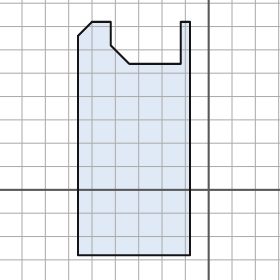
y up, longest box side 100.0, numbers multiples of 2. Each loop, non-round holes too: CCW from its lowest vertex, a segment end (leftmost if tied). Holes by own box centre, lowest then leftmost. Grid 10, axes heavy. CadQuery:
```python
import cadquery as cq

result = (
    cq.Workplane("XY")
    .moveTo(-56.0, -28.0)
    .lineTo(-8.0, -28.0)
    .lineTo(-8.0, 72.0)
    .lineTo(-12.0, 72.0)
    .lineTo(-12.0, 54.0)
    .lineTo(-34.0, 54.0)
    .lineTo(-42.0, 62.0)
    .lineTo(-42.0, 72.0)
    .lineTo(-50.0, 72.0)
    .lineTo(-56.0, 66.0)
    .close()
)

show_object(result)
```